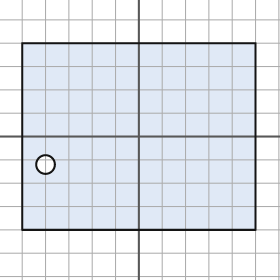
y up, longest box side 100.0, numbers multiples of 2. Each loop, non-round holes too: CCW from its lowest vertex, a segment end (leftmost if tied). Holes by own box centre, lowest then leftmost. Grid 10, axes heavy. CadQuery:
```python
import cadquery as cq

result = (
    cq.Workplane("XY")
    .moveTo(-50.0, -40.0)
    .lineTo(50.0, -40.0)
    .lineTo(50.0, 40.0)
    .lineTo(-50.0, 40.0)
    .close()
    .moveTo(-40.0, -12.0)
    .circle(4.0)
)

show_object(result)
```